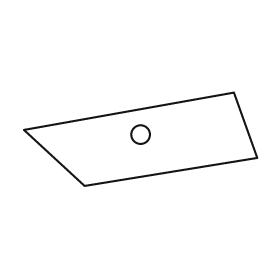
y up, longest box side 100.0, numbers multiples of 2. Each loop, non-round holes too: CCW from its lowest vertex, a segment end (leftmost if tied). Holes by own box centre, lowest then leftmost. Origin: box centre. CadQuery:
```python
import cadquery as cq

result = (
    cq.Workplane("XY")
    .moveTo(-24.0, -20.0)
    .lineTo(50.0, -8.0)
    .lineTo(40.0, 20.0)
    .lineTo(-50.0, 4.0)
    .close()
    .moveTo(0.0, 2.0)
    .circle(4.0)
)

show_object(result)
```